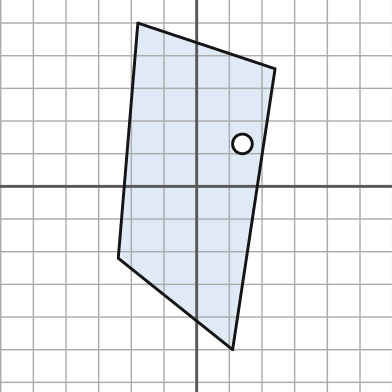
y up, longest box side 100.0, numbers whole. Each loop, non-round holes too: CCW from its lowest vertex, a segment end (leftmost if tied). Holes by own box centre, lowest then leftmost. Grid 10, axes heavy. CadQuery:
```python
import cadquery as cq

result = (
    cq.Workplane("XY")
    .moveTo(11.0, -50.0)
    .lineTo(24.0, 36.0)
    .lineTo(-18.0, 50.0)
    .lineTo(-24.0, -22.0)
    .close()
    .moveTo(14.0, 13.0)
    .circle(3.0)
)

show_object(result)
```